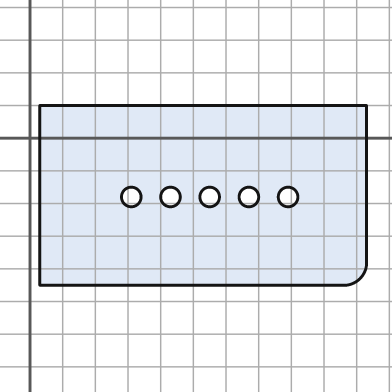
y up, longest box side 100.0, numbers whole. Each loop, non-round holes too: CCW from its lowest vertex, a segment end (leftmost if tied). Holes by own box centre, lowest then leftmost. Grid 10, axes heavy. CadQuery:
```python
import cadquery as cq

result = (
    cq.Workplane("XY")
    .moveTo(3.0, -45.0)
    .lineTo(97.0, -45.0)
    .threePointArc((101.0, -43.0), (103.0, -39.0))
    .lineTo(103.0, 10.0)
    .lineTo(3.0, 10.0)
    .close()
    .moveTo(31.0, -18.0)
    .circle(3.0)
    .moveTo(43.0, -18.0)
    .circle(3.0)
    .moveTo(55.0, -18.0)
    .circle(3.0)
    .moveTo(67.0, -18.0)
    .circle(3.0)
    .moveTo(79.0, -18.0)
    .circle(3.0)
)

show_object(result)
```